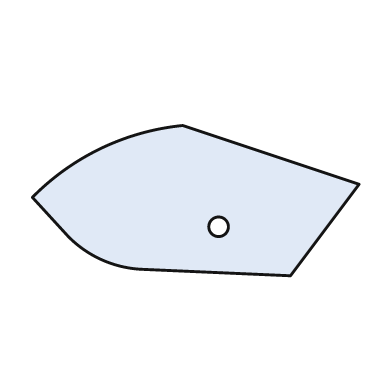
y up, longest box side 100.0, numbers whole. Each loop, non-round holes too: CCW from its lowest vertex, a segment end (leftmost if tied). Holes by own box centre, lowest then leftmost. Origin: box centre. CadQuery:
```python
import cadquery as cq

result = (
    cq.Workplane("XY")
    .moveTo(29.0, -23.0)
    .lineTo(50.0, 5.0)
    .lineTo(-4.0, 23.0)
    .threePointArc((-29.0, 16.0), (-50.0, 1.0))
    .lineTo(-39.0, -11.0)
    .threePointArc((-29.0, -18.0), (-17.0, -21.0))
    .close()
    .moveTo(7.0, -8.0)
    .circle(3.0)
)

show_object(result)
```